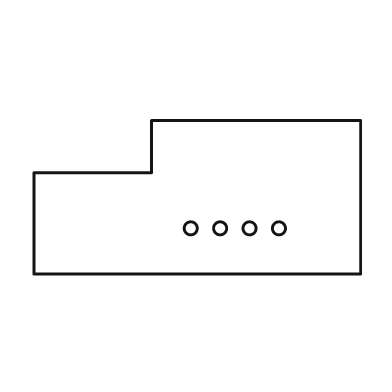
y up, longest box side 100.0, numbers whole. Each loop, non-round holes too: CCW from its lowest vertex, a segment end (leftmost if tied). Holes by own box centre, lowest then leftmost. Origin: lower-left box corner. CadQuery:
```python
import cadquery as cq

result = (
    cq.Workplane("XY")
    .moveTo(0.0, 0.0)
    .lineTo(100.0, 0.0)
    .lineTo(100.0, 47.0)
    .lineTo(36.0, 47.0)
    .lineTo(36.0, 31.0)
    .lineTo(0.0, 31.0)
    .close()
    .moveTo(48.0, 14.0)
    .circle(2.0)
    .moveTo(57.0, 14.0)
    .circle(2.0)
    .moveTo(66.0, 14.0)
    .circle(2.0)
    .moveTo(75.0, 14.0)
    .circle(2.0)
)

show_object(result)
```